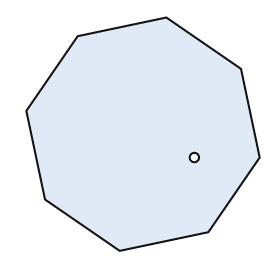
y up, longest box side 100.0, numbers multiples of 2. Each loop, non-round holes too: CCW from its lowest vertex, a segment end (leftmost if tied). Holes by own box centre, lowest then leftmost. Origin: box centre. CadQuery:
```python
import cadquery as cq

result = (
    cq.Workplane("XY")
    .moveTo(-10.0, -50.0)
    .lineTo(28.0, -42.0)
    .lineTo(50.0, -10.0)
    .lineTo(42.0, 28.0)
    .lineTo(10.0, 50.0)
    .lineTo(-28.0, 42.0)
    .lineTo(-50.0, 10.0)
    .lineTo(-42.0, -28.0)
    .close()
    .moveTo(22.0, -10.0)
    .circle(2.0)
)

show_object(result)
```